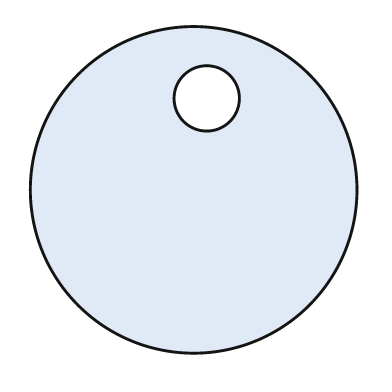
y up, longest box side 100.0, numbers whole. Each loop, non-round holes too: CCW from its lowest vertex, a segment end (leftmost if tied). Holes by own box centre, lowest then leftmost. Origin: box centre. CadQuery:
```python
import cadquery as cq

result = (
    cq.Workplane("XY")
    .moveTo(0.0, 0.0)
    .circle(50.0)
    .moveTo(4.0, 28.0)
    .circle(10.0)
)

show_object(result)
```